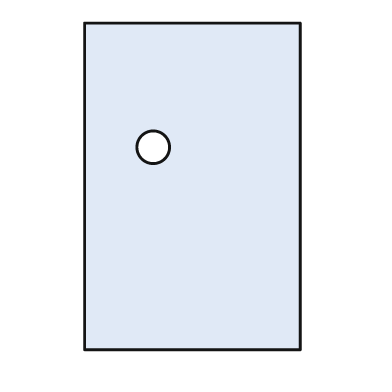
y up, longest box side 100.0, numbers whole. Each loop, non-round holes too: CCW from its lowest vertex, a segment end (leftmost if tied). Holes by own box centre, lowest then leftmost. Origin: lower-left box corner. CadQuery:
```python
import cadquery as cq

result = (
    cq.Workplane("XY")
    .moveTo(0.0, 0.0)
    .lineTo(66.0, 0.0)
    .lineTo(66.0, 100.0)
    .lineTo(0.0, 100.0)
    .close()
    .moveTo(21.0, 62.0)
    .circle(5.0)
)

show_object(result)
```